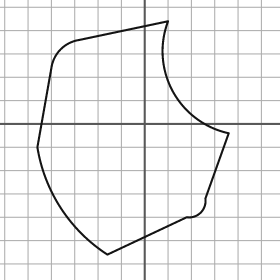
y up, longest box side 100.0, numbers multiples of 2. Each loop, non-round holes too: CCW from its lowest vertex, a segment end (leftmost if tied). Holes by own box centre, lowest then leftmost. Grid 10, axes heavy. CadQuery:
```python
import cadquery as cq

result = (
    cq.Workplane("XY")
    .moveTo(-16.0, -56.0)
    .lineTo(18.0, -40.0)
    .threePointArc((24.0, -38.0), (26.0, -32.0))
    .lineTo(36.0, -4.0)
    .threePointArc((12.0, 14.0), (10.0, 44.0))
    .lineTo(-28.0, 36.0)
    .threePointArc((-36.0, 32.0), (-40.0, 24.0))
    .lineTo(-46.0, -10.0)
    .threePointArc((-36.0, -36.0), (-16.0, -56.0))
    .close()
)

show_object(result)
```